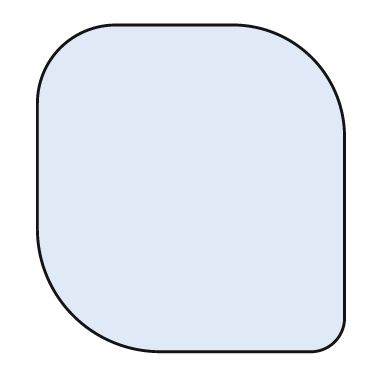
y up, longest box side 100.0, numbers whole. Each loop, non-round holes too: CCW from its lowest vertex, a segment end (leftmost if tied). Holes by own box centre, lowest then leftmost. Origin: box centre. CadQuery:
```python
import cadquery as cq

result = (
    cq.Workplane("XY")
    .moveTo(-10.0, -50.0)
    .lineTo(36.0, -50.0)
    .threePointArc((44.0, -47.0), (47.0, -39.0))
    .lineTo(47.0, 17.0)
    .threePointArc((37.0, 40.0), (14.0, 50.0))
    .lineTo(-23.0, 50.0)
    .threePointArc((-40.0, 43.0), (-47.0, 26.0))
    .lineTo(-47.0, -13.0)
    .threePointArc((-36.0, -39.0), (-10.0, -50.0))
    .close()
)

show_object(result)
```